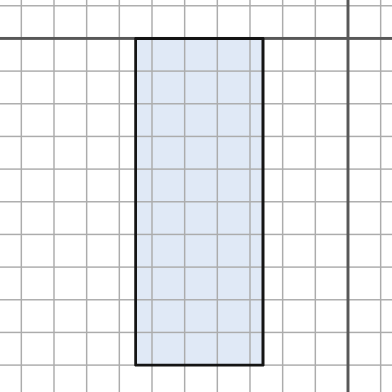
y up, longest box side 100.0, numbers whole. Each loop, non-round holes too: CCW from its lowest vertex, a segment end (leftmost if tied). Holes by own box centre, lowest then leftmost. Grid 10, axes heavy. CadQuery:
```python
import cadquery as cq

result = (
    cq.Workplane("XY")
    .moveTo(-65.0, -100.0)
    .lineTo(-26.0, -100.0)
    .lineTo(-26.0, 0.0)
    .lineTo(-65.0, 0.0)
    .close()
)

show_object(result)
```